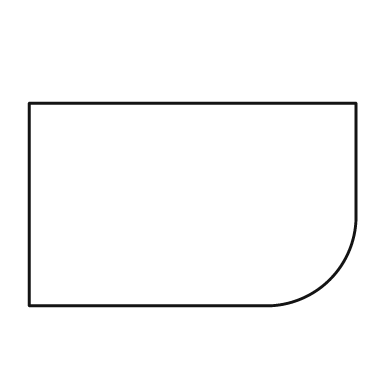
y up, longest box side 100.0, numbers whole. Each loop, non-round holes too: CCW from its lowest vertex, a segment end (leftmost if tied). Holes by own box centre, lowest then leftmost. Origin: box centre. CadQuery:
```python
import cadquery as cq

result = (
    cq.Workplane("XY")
    .moveTo(-50.0, -31.0)
    .lineTo(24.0, -31.0)
    .threePointArc((42.0, -23.0), (50.0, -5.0))
    .lineTo(50.0, 31.0)
    .lineTo(-50.0, 31.0)
    .close()
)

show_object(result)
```